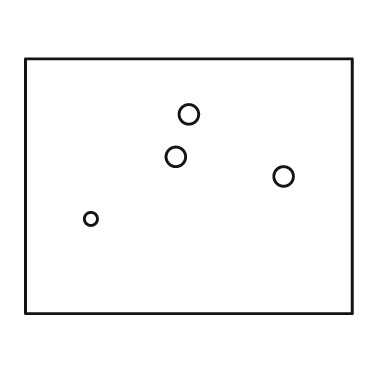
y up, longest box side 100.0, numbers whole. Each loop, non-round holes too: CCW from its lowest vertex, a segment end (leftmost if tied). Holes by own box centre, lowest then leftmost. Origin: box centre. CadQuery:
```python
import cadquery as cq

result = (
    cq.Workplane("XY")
    .moveTo(-50.0, -39.0)
    .lineTo(50.0, -39.0)
    .lineTo(50.0, 39.0)
    .lineTo(-50.0, 39.0)
    .close()
    .moveTo(-30.0, -10.0)
    .circle(2.0)
    .moveTo(29.0, 3.0)
    .circle(3.0)
    .moveTo(-4.0, 9.0)
    .circle(3.0)
    .moveTo(0.0, 22.0)
    .circle(3.0)
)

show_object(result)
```